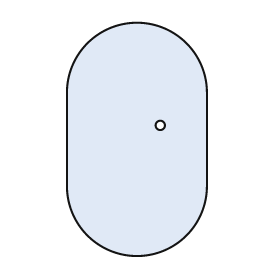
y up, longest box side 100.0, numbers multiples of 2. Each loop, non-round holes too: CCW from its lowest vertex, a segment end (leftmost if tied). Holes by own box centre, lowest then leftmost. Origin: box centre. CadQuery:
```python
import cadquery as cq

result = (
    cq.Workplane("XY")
    .moveTo(-30.0, -20.0)
    .threePointArc((0.0, -50.0), (30.0, -20.0))
    .lineTo(30.0, 20.0)
    .threePointArc((0.0, 50.0), (-30.0, 20.0))
    .close()
    .moveTo(10.0, 6.0)
    .circle(2.0)
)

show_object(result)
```